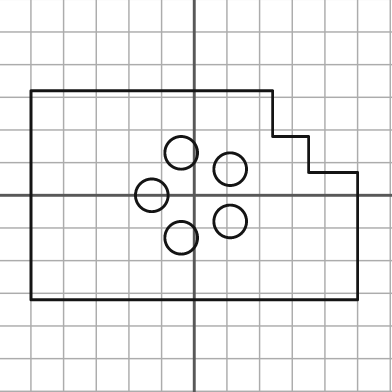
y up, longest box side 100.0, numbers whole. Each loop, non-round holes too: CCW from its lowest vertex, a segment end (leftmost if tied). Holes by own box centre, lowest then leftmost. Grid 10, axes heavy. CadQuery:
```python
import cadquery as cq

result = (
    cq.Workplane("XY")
    .moveTo(-50.0, -32.0)
    .lineTo(50.0, -32.0)
    .lineTo(50.0, 7.0)
    .lineTo(35.0, 7.0)
    .lineTo(35.0, 18.0)
    .lineTo(24.0, 18.0)
    .lineTo(24.0, 32.0)
    .lineTo(-50.0, 32.0)
    .close()
    .moveTo(-4.0, -13.0)
    .circle(5.0)
    .moveTo(11.0, -8.0)
    .circle(5.0)
    .moveTo(-13.0, 0.0)
    .circle(5.0)
    .moveTo(11.0, 8.0)
    .circle(5.0)
    .moveTo(-4.0, 13.0)
    .circle(5.0)
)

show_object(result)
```